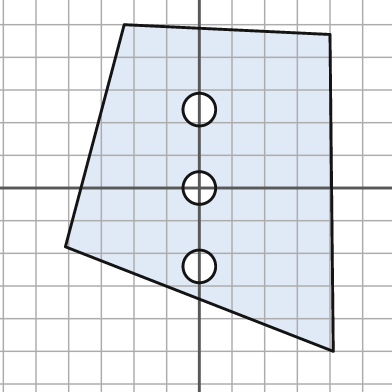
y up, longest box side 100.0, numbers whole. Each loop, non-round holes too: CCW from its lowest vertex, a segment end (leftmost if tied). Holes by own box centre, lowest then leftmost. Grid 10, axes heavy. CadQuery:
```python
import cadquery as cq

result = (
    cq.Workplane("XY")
    .moveTo(41.0, -50.0)
    .lineTo(40.0, 47.0)
    .lineTo(-23.0, 50.0)
    .lineTo(-41.0, -18.0)
    .close()
    .moveTo(0.0, -24.0)
    .circle(5.0)
    .moveTo(0.0, 0.0)
    .circle(5.0)
    .moveTo(0.0, 24.0)
    .circle(5.0)
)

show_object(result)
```